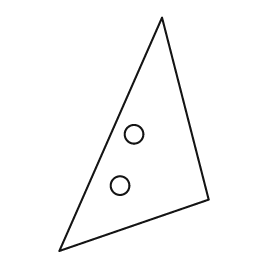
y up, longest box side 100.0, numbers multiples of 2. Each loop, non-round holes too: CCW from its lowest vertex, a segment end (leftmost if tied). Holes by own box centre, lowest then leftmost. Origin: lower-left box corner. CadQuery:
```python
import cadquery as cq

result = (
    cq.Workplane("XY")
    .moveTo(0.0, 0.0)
    .lineTo(64.0, 22.0)
    .lineTo(44.0, 100.0)
    .close()
    .moveTo(26.0, 28.0)
    .circle(4.0)
    .moveTo(32.0, 50.0)
    .circle(4.0)
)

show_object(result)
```